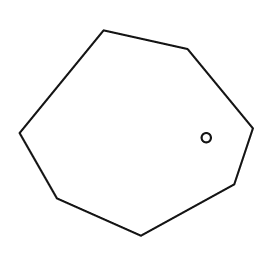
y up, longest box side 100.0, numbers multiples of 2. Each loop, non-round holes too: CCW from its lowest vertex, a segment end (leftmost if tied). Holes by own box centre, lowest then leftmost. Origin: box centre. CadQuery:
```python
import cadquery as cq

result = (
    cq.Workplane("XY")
    .moveTo(2.0, -44.0)
    .lineTo(42.0, -22.0)
    .lineTo(50.0, 2.0)
    .lineTo(22.0, 36.0)
    .lineTo(-14.0, 44.0)
    .lineTo(-50.0, 0.0)
    .lineTo(-34.0, -28.0)
    .close()
    .moveTo(30.0, -2.0)
    .circle(2.0)
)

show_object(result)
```